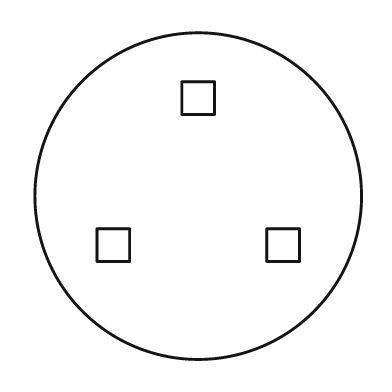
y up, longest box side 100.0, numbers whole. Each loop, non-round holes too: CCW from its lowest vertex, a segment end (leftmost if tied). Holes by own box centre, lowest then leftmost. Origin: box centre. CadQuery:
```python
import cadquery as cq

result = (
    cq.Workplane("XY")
    .moveTo(0.0, 0.0)
    .circle(50.0)
    .moveTo(-31.0, -20.0)
    .lineTo(-21.0, -20.0)
    .lineTo(-21.0, -10.0)
    .lineTo(-31.0, -10.0)
    .close()
    .moveTo(21.0, -20.0)
    .lineTo(31.0, -20.0)
    .lineTo(31.0, -10.0)
    .lineTo(21.0, -10.0)
    .close()
    .moveTo(-5.0, 25.0)
    .lineTo(5.0, 25.0)
    .lineTo(5.0, 35.0)
    .lineTo(-5.0, 35.0)
    .close()
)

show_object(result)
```